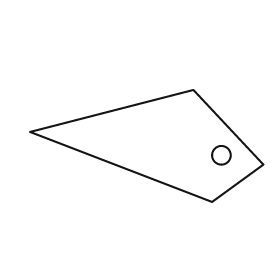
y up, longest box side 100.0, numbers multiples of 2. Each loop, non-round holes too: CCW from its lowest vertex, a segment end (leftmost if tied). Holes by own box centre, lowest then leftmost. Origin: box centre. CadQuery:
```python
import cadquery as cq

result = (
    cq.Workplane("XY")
    .moveTo(28.0, -24.0)
    .lineTo(50.0, -8.0)
    .lineTo(20.0, 24.0)
    .lineTo(-50.0, 6.0)
    .close()
    .moveTo(32.0, -4.0)
    .circle(4.0)
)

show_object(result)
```